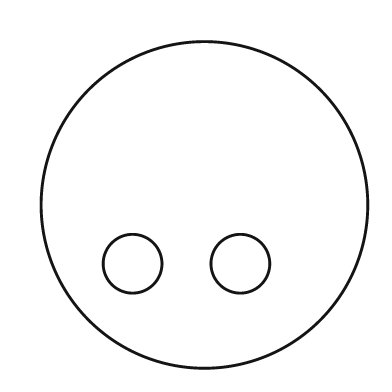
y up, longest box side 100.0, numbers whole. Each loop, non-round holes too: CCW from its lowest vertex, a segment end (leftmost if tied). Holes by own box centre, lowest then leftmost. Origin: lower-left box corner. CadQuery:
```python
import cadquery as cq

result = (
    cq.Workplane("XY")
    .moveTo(50.0, 50.0)
    .circle(50.0)
    .moveTo(28.0, 32.0)
    .circle(9.0)
    .moveTo(61.0, 32.0)
    .circle(9.0)
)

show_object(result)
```